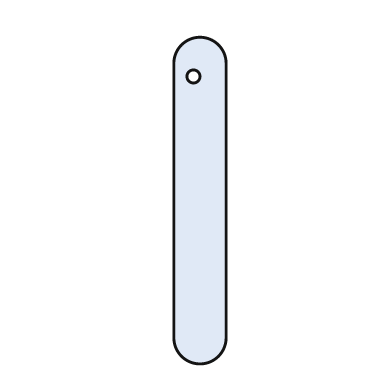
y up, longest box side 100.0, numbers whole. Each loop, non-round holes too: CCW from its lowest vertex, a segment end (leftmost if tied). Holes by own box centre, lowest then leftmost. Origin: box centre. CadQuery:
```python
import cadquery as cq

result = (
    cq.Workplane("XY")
    .moveTo(-8.0, -42.0)
    .threePointArc((0.0, -50.0), (8.0, -42.0))
    .lineTo(8.0, 42.0)
    .threePointArc((0.0, 50.0), (-8.0, 42.0))
    .close()
    .moveTo(-2.0, 38.0)
    .circle(2.0)
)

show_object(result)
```